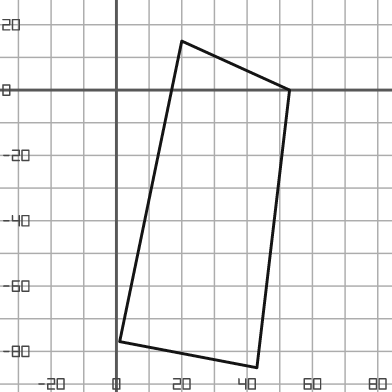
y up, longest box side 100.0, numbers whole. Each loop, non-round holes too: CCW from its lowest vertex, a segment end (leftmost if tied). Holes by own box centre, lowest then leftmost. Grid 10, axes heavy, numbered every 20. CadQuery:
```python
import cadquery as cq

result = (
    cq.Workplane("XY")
    .moveTo(43.0, -85.0)
    .lineTo(53.0, 0.0)
    .lineTo(20.0, 15.0)
    .lineTo(1.0, -77.0)
    .close()
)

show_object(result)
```